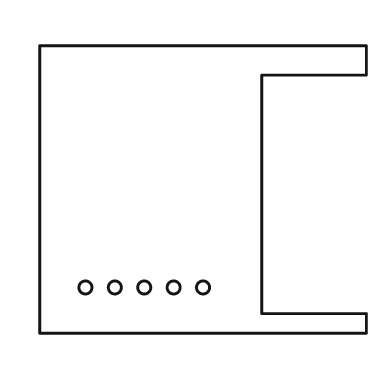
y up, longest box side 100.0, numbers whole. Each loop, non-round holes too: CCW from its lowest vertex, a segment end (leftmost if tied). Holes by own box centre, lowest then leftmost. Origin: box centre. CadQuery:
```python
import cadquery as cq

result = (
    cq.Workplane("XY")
    .moveTo(-50.0, -44.0)
    .lineTo(50.0, -44.0)
    .lineTo(50.0, -38.0)
    .lineTo(18.0, -38.0)
    .lineTo(18.0, 35.0)
    .lineTo(50.0, 35.0)
    .lineTo(50.0, 44.0)
    .lineTo(-50.0, 44.0)
    .close()
    .moveTo(-36.0, -30.0)
    .circle(2.0)
    .moveTo(-27.0, -30.0)
    .circle(2.0)
    .moveTo(-18.0, -30.0)
    .circle(2.0)
    .moveTo(-9.0, -30.0)
    .circle(2.0)
    .moveTo(0.0, -30.0)
    .circle(2.0)
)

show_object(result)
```